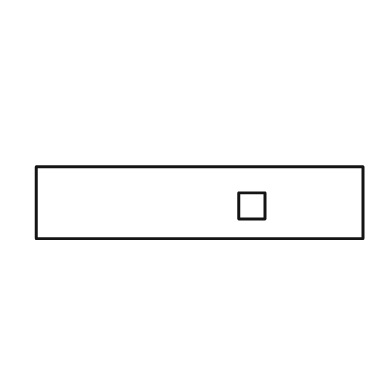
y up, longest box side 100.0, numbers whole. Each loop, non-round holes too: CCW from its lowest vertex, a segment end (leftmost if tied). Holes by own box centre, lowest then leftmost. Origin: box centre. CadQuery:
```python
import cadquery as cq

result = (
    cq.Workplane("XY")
    .moveTo(-50.0, -11.0)
    .lineTo(50.0, -11.0)
    .lineTo(50.0, 11.0)
    .lineTo(-50.0, 11.0)
    .close()
    .moveTo(12.0, -5.0)
    .lineTo(20.0, -5.0)
    .lineTo(20.0, 3.0)
    .lineTo(12.0, 3.0)
    .close()
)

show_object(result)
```